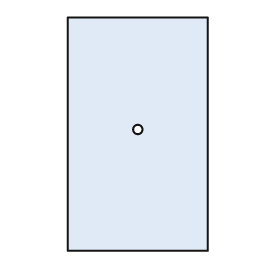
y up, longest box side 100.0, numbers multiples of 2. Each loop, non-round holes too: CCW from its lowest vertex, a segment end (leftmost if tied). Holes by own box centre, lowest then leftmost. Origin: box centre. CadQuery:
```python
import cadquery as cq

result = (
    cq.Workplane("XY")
    .moveTo(-30.0, -50.0)
    .lineTo(30.0, -50.0)
    .lineTo(30.0, 50.0)
    .lineTo(-30.0, 50.0)
    .close()
    .moveTo(0.0, 2.0)
    .circle(2.0)
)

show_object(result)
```